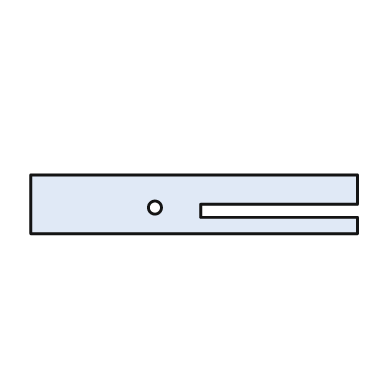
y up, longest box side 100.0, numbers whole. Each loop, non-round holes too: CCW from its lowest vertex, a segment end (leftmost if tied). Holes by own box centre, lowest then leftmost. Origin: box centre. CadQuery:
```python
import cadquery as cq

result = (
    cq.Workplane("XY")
    .moveTo(-50.0, -9.0)
    .lineTo(50.0, -9.0)
    .lineTo(50.0, -4.0)
    .lineTo(2.0, -4.0)
    .lineTo(2.0, 0.0)
    .lineTo(50.0, 0.0)
    .lineTo(50.0, 9.0)
    .lineTo(-50.0, 9.0)
    .close()
    .moveTo(-12.0, -1.0)
    .circle(2.0)
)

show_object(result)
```